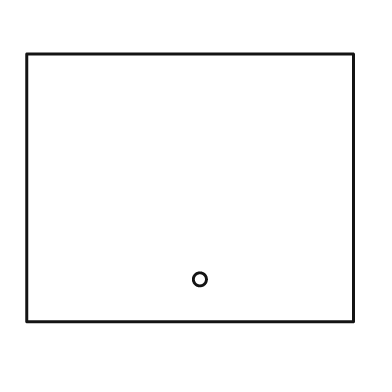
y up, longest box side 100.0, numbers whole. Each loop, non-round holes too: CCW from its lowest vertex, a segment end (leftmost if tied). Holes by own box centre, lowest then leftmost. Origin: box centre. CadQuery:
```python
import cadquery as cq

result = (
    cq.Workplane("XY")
    .moveTo(-50.0, -41.0)
    .lineTo(50.0, -41.0)
    .lineTo(50.0, 41.0)
    .lineTo(-50.0, 41.0)
    .close()
    .moveTo(3.0, -28.0)
    .circle(2.0)
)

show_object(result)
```